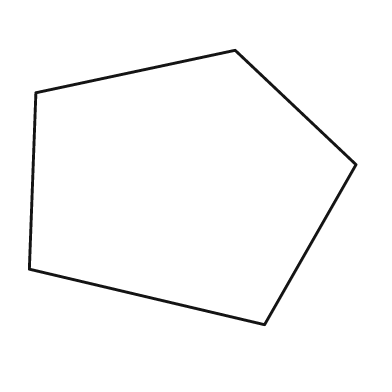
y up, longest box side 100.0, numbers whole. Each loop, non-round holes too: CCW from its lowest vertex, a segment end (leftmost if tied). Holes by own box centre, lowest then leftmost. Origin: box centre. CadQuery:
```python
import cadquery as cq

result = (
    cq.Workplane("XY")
    .moveTo(22.0, -42.0)
    .lineTo(50.0, 7.0)
    .lineTo(13.0, 42.0)
    .lineTo(-48.0, 29.0)
    .lineTo(-50.0, -25.0)
    .close()
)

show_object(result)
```